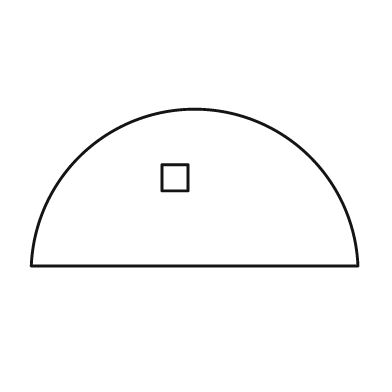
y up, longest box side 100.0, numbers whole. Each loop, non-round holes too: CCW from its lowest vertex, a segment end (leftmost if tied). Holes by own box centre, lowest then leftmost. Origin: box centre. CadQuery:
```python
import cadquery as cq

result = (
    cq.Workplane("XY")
    .moveTo(-50.0, -24.0)
    .lineTo(50.0, -24.0)
    .threePointArc((0.0, 24.0), (-50.0, -24.0))
    .close()
    .moveTo(-10.0, -1.0)
    .lineTo(-2.0, -1.0)
    .lineTo(-2.0, 7.0)
    .lineTo(-10.0, 7.0)
    .close()
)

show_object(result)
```